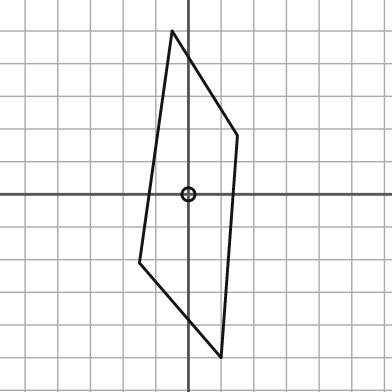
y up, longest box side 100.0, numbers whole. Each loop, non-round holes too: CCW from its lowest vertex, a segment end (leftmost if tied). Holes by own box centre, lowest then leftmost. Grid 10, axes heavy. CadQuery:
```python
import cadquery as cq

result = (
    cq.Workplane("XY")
    .moveTo(10.0, -50.0)
    .lineTo(15.0, 18.0)
    .lineTo(-5.0, 50.0)
    .lineTo(-15.0, -21.0)
    .close()
    .moveTo(0.0, 0.0)
    .circle(2.0)
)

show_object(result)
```